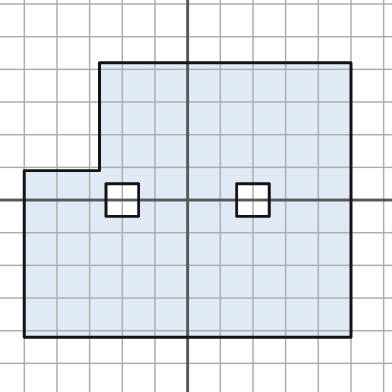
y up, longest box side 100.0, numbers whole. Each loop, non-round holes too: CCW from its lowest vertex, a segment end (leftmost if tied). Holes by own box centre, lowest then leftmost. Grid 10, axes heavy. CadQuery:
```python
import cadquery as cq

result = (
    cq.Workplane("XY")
    .moveTo(-50.0, -42.0)
    .lineTo(50.0, -42.0)
    .lineTo(50.0, 42.0)
    .lineTo(-27.0, 42.0)
    .lineTo(-27.0, 9.0)
    .lineTo(-50.0, 9.0)
    .close()
    .moveTo(-25.0, -5.0)
    .lineTo(-15.0, -5.0)
    .lineTo(-15.0, 5.0)
    .lineTo(-25.0, 5.0)
    .close()
    .moveTo(15.0, -5.0)
    .lineTo(25.0, -5.0)
    .lineTo(25.0, 5.0)
    .lineTo(15.0, 5.0)
    .close()
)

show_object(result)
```